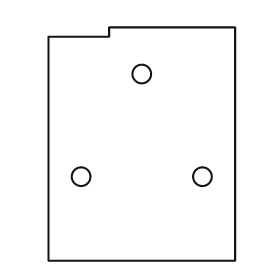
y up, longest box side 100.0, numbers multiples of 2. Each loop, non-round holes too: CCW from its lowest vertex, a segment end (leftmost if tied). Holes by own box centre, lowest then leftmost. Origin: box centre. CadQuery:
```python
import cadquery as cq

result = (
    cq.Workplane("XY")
    .moveTo(-40.0, -50.0)
    .lineTo(40.0, -50.0)
    .lineTo(40.0, 50.0)
    .lineTo(-14.0, 50.0)
    .lineTo(-14.0, 46.0)
    .lineTo(-40.0, 46.0)
    .close()
    .moveTo(-26.0, -14.0)
    .circle(4.0)
    .moveTo(26.0, -14.0)
    .circle(4.0)
    .moveTo(0.0, 30.0)
    .circle(4.0)
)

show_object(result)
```